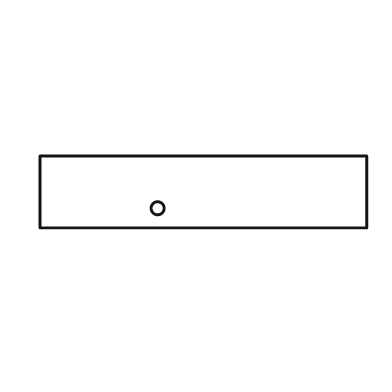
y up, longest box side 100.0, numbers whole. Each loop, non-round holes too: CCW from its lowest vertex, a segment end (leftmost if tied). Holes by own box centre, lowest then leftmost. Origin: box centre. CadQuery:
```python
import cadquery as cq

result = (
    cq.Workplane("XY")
    .moveTo(-50.0, -11.0)
    .lineTo(50.0, -11.0)
    .lineTo(50.0, 11.0)
    .lineTo(-50.0, 11.0)
    .close()
    .moveTo(-14.0, -5.0)
    .circle(2.0)
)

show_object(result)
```